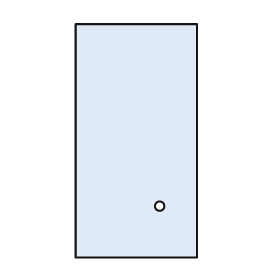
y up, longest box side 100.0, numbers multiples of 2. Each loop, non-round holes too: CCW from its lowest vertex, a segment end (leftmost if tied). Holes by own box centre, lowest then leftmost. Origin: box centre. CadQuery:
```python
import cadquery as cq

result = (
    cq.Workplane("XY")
    .moveTo(-26.0, -50.0)
    .lineTo(26.0, -50.0)
    .lineTo(26.0, 50.0)
    .lineTo(-26.0, 50.0)
    .close()
    .moveTo(10.0, -28.0)
    .circle(2.0)
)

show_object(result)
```